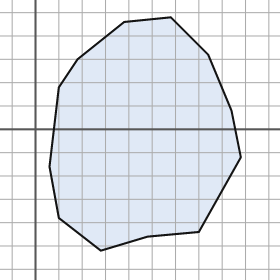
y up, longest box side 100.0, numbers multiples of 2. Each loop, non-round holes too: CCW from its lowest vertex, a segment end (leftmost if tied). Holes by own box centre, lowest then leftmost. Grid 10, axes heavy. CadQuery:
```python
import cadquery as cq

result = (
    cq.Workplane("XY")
    .moveTo(28.0, -52.0)
    .lineTo(48.0, -46.0)
    .lineTo(70.0, -44.0)
    .lineTo(88.0, -12.0)
    .lineTo(84.0, 8.0)
    .lineTo(74.0, 32.0)
    .lineTo(58.0, 48.0)
    .lineTo(38.0, 46.0)
    .lineTo(18.0, 30.0)
    .lineTo(10.0, 18.0)
    .lineTo(6.0, -16.0)
    .lineTo(10.0, -38.0)
    .close()
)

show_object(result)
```